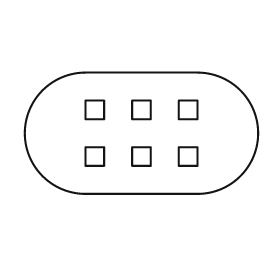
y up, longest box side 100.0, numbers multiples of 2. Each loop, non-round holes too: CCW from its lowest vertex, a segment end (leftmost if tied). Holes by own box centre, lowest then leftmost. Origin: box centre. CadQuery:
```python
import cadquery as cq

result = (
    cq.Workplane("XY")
    .moveTo(-24.0, -26.0)
    .lineTo(24.0, -26.0)
    .threePointArc((50.0, 0.0), (24.0, 26.0))
    .lineTo(-24.0, 26.0)
    .threePointArc((-50.0, 0.0), (-24.0, -26.0))
    .close()
    .moveTo(-24.0, -14.0)
    .lineTo(-16.0, -14.0)
    .lineTo(-16.0, -6.0)
    .lineTo(-24.0, -6.0)
    .close()
    .moveTo(-4.0, -14.0)
    .lineTo(4.0, -14.0)
    .lineTo(4.0, -6.0)
    .lineTo(-4.0, -6.0)
    .close()
    .moveTo(16.0, -14.0)
    .lineTo(24.0, -14.0)
    .lineTo(24.0, -6.0)
    .lineTo(16.0, -6.0)
    .close()
    .moveTo(-24.0, 6.0)
    .lineTo(-16.0, 6.0)
    .lineTo(-16.0, 14.0)
    .lineTo(-24.0, 14.0)
    .close()
    .moveTo(-4.0, 6.0)
    .lineTo(4.0, 6.0)
    .lineTo(4.0, 14.0)
    .lineTo(-4.0, 14.0)
    .close()
    .moveTo(16.0, 6.0)
    .lineTo(24.0, 6.0)
    .lineTo(24.0, 14.0)
    .lineTo(16.0, 14.0)
    .close()
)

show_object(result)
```